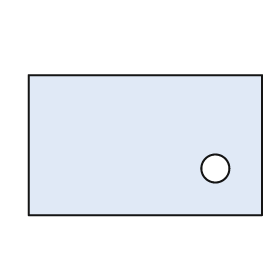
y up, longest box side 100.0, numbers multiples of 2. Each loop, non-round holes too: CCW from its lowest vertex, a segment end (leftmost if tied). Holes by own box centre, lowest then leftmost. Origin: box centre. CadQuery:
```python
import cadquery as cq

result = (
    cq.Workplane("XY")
    .moveTo(-50.0, -30.0)
    .lineTo(50.0, -30.0)
    .lineTo(50.0, 30.0)
    .lineTo(-50.0, 30.0)
    .close()
    .moveTo(30.0, -10.0)
    .circle(6.0)
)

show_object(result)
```